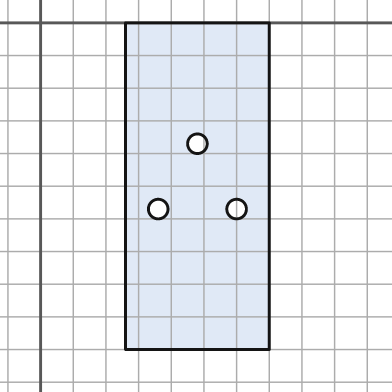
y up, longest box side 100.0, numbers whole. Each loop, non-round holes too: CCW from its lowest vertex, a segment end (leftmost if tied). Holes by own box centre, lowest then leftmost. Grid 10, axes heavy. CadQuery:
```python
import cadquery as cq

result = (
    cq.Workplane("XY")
    .moveTo(26.0, -100.0)
    .lineTo(70.0, -100.0)
    .lineTo(70.0, 0.0)
    .lineTo(26.0, 0.0)
    .close()
    .moveTo(36.0, -57.0)
    .circle(3.0)
    .moveTo(60.0, -57.0)
    .circle(3.0)
    .moveTo(48.0, -37.0)
    .circle(3.0)
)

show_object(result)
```